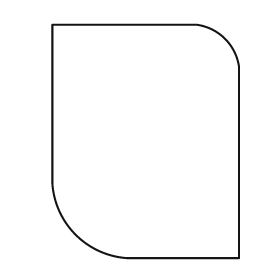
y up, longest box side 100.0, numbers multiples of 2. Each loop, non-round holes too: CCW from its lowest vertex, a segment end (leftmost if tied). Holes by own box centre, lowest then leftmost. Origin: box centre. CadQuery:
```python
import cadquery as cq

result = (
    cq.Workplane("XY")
    .moveTo(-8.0, -50.0)
    .lineTo(40.0, -50.0)
    .lineTo(40.0, 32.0)
    .threePointArc((34.0, 44.0), (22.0, 50.0))
    .lineTo(-40.0, 50.0)
    .lineTo(-40.0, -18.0)
    .threePointArc((-30.0, -40.0), (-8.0, -50.0))
    .close()
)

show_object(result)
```